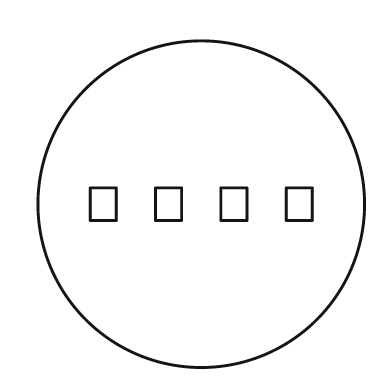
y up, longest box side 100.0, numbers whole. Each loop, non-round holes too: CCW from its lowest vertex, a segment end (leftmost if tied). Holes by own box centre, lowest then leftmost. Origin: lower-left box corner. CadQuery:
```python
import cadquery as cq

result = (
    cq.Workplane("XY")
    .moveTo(50.0, 50.0)
    .circle(50.0)
    .moveTo(16.0, 45.0)
    .lineTo(24.0, 45.0)
    .lineTo(24.0, 55.0)
    .lineTo(16.0, 55.0)
    .close()
    .moveTo(36.0, 45.0)
    .lineTo(44.0, 45.0)
    .lineTo(44.0, 55.0)
    .lineTo(36.0, 55.0)
    .close()
    .moveTo(56.0, 45.0)
    .lineTo(64.0, 45.0)
    .lineTo(64.0, 55.0)
    .lineTo(56.0, 55.0)
    .close()
    .moveTo(76.0, 45.0)
    .lineTo(84.0, 45.0)
    .lineTo(84.0, 55.0)
    .lineTo(76.0, 55.0)
    .close()
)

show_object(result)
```